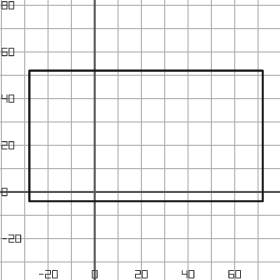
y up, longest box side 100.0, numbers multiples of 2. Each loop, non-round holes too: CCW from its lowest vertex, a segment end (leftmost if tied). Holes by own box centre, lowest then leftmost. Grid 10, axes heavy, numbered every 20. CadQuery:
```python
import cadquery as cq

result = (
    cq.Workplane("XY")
    .moveTo(-28.0, -4.0)
    .lineTo(72.0, -4.0)
    .lineTo(72.0, 52.0)
    .lineTo(-28.0, 52.0)
    .close()
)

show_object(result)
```